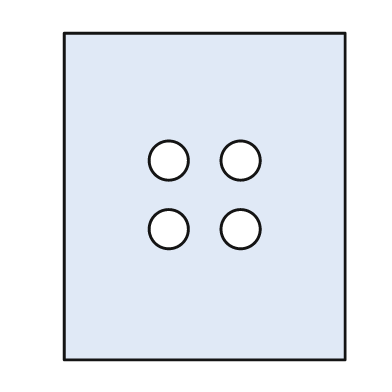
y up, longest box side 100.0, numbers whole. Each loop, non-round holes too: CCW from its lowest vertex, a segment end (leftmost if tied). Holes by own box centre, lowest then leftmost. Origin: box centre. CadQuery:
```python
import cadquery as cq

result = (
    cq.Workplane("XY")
    .moveTo(-43.0, -50.0)
    .lineTo(43.0, -50.0)
    .lineTo(43.0, 50.0)
    .lineTo(-43.0, 50.0)
    .close()
    .moveTo(-11.0, -10.0)
    .circle(6.0)
    .moveTo(11.0, -10.0)
    .circle(6.0)
    .moveTo(-11.0, 11.0)
    .circle(6.0)
    .moveTo(11.0, 11.0)
    .circle(6.0)
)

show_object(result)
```